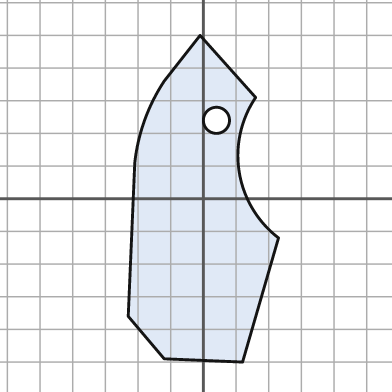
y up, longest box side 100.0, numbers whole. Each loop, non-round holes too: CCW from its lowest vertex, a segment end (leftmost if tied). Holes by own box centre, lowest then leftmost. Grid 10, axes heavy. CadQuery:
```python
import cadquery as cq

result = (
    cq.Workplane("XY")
    .moveTo(12.0, -50.0)
    .lineTo(23.0, -12.0)
    .threePointArc((11.0, 8.0), (16.0, 31.0))
    .lineTo(-1.0, 50.0)
    .lineTo(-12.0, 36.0)
    .threePointArc((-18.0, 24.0), (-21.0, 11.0))
    .lineTo(-23.0, -36.0)
    .lineTo(-12.0, -49.0)
    .close()
    .moveTo(4.0, 24.0)
    .circle(4.0)
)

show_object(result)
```